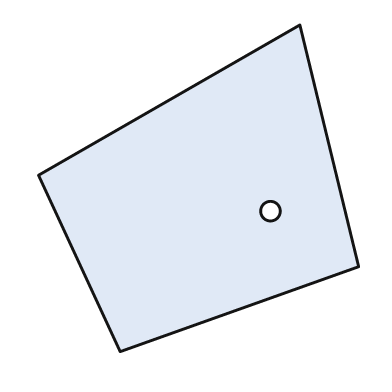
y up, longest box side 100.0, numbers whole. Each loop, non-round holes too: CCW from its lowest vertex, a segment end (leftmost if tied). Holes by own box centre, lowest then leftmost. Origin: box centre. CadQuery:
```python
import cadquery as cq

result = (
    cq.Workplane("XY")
    .moveTo(-24.0, -50.0)
    .lineTo(49.0, -24.0)
    .lineTo(31.0, 50.0)
    .lineTo(-49.0, 4.0)
    .close()
    .moveTo(22.0, -7.0)
    .circle(3.0)
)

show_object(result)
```